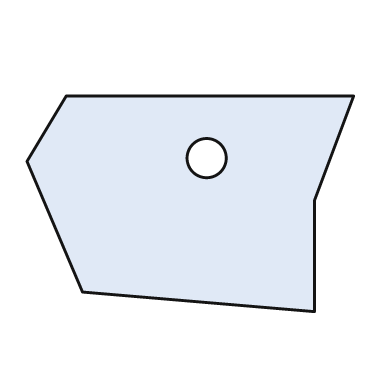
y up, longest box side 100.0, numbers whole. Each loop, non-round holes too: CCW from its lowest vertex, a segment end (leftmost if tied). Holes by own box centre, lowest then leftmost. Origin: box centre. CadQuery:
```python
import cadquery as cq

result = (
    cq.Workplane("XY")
    .moveTo(38.0, -33.0)
    .lineTo(38.0, 1.0)
    .lineTo(50.0, 33.0)
    .lineTo(-38.0, 33.0)
    .lineTo(-50.0, 13.0)
    .lineTo(-33.0, -27.0)
    .close()
    .moveTo(5.0, 14.0)
    .circle(6.0)
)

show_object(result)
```